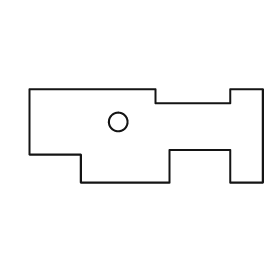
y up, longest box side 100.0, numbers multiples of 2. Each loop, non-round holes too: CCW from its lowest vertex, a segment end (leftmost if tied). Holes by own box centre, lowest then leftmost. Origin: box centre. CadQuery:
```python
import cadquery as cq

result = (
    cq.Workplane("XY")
    .moveTo(-28.0, -20.0)
    .lineTo(10.0, -20.0)
    .lineTo(10.0, -6.0)
    .lineTo(36.0, -6.0)
    .lineTo(36.0, -20.0)
    .lineTo(50.0, -20.0)
    .lineTo(50.0, 20.0)
    .lineTo(36.0, 20.0)
    .lineTo(36.0, 14.0)
    .lineTo(4.0, 14.0)
    .lineTo(4.0, 20.0)
    .lineTo(-50.0, 20.0)
    .lineTo(-50.0, -8.0)
    .lineTo(-28.0, -8.0)
    .close()
    .moveTo(-12.0, 6.0)
    .circle(4.0)
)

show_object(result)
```